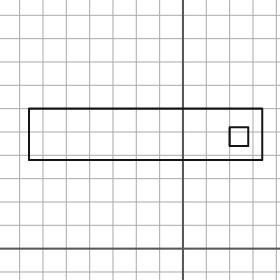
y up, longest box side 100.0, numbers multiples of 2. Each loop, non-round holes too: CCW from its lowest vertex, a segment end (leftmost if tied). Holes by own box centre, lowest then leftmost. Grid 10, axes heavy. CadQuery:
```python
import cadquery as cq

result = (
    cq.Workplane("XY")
    .moveTo(-66.0, 38.0)
    .lineTo(34.0, 38.0)
    .lineTo(34.0, 60.0)
    .lineTo(-66.0, 60.0)
    .close()
    .moveTo(20.0, 44.0)
    .lineTo(28.0, 44.0)
    .lineTo(28.0, 52.0)
    .lineTo(20.0, 52.0)
    .close()
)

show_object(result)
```